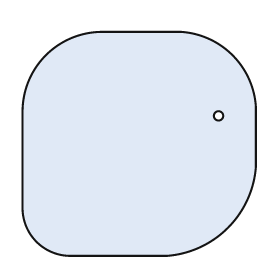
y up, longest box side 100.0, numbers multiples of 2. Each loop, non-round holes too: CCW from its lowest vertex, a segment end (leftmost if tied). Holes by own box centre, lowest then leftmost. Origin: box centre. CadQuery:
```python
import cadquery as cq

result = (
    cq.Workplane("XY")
    .moveTo(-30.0, -48.0)
    .lineTo(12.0, -48.0)
    .threePointArc((38.0, -36.0), (50.0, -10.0))
    .lineTo(50.0, 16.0)
    .threePointArc((40.0, 38.0), (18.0, 48.0))
    .lineTo(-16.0, 48.0)
    .threePointArc((-40.0, 38.0), (-50.0, 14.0))
    .lineTo(-50.0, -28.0)
    .threePointArc((-44.0, -42.0), (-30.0, -48.0))
    .close()
    .moveTo(34.0, 12.0)
    .circle(2.0)
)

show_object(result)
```